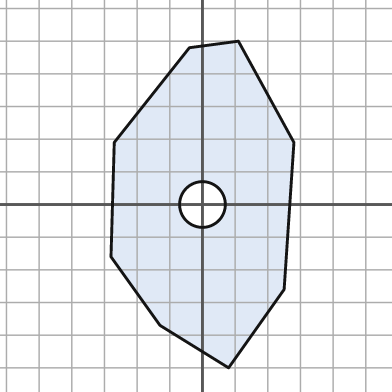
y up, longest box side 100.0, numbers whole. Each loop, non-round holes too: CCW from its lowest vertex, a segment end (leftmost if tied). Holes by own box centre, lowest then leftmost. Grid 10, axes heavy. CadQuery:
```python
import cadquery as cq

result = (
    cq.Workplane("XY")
    .moveTo(8.0, -50.0)
    .lineTo(25.0, -26.0)
    .lineTo(28.0, 19.0)
    .lineTo(11.0, 50.0)
    .lineTo(-4.0, 48.0)
    .lineTo(-27.0, 19.0)
    .lineTo(-28.0, -16.0)
    .lineTo(-13.0, -37.0)
    .close()
    .moveTo(0.0, 0.0)
    .circle(7.0)
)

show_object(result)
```